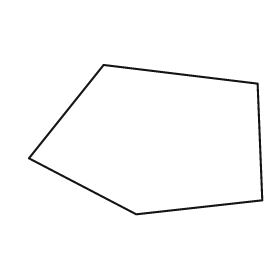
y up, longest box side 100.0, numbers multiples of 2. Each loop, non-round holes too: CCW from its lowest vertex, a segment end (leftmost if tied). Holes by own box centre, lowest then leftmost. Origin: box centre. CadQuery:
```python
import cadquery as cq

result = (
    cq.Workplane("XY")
    .moveTo(-4.0, -32.0)
    .lineTo(50.0, -26.0)
    .lineTo(48.0, 24.0)
    .lineTo(-18.0, 32.0)
    .lineTo(-50.0, -8.0)
    .close()
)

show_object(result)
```